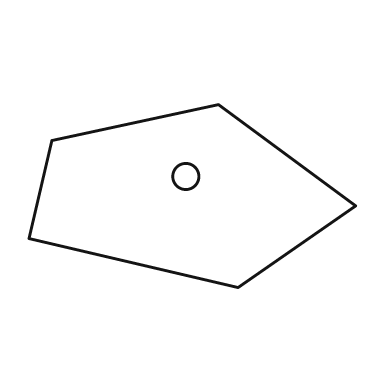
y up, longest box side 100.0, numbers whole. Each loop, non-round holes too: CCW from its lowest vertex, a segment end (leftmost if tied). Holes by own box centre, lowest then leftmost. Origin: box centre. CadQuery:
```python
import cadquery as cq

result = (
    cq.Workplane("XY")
    .moveTo(14.0, -28.0)
    .lineTo(50.0, -3.0)
    .lineTo(8.0, 28.0)
    .lineTo(-43.0, 17.0)
    .lineTo(-50.0, -13.0)
    .close()
    .moveTo(-2.0, 6.0)
    .circle(4.0)
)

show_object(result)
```